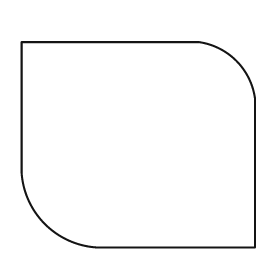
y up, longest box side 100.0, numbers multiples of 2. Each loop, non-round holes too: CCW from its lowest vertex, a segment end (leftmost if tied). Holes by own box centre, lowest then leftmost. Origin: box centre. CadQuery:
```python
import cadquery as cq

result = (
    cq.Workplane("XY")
    .moveTo(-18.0, -44.0)
    .lineTo(50.0, -44.0)
    .lineTo(50.0, 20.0)
    .threePointArc((42.0, 36.0), (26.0, 44.0))
    .lineTo(-50.0, 44.0)
    .lineTo(-50.0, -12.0)
    .threePointArc((-40.0, -34.0), (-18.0, -44.0))
    .close()
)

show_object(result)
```